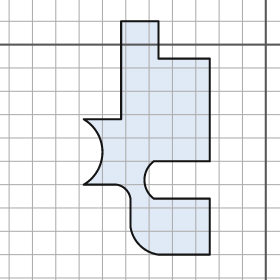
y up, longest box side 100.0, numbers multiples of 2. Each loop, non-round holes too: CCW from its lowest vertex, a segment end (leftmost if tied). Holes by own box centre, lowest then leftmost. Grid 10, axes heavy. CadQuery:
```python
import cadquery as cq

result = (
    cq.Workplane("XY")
    .moveTo(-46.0, -90.0)
    .lineTo(-24.0, -90.0)
    .lineTo(-24.0, -66.0)
    .lineTo(-48.0, -66.0)
    .threePointArc((-52.0, -58.0), (-48.0, -50.0))
    .lineTo(-24.0, -50.0)
    .lineTo(-24.0, -6.0)
    .lineTo(-46.0, -6.0)
    .lineTo(-46.0, 10.0)
    .lineTo(-62.0, 10.0)
    .lineTo(-62.0, -32.0)
    .lineTo(-78.0, -32.0)
    .threePointArc((-70.0, -46.0), (-78.0, -60.0))
    .lineTo(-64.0, -60.0)
    .threePointArc((-60.0, -62.0), (-58.0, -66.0))
    .lineTo(-58.0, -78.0)
    .threePointArc((-54.0, -86.0), (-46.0, -90.0))
    .close()
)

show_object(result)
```